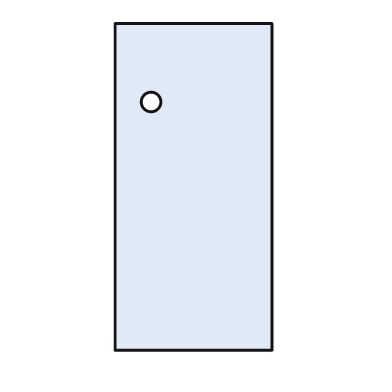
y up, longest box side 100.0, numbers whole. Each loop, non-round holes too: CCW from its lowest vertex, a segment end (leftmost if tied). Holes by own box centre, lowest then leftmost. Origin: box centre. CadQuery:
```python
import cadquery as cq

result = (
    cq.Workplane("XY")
    .moveTo(-24.0, -50.0)
    .lineTo(24.0, -50.0)
    .lineTo(24.0, 50.0)
    .lineTo(-24.0, 50.0)
    .close()
    .moveTo(-13.0, 26.0)
    .circle(3.0)
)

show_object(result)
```